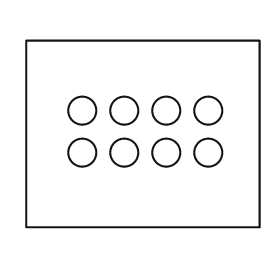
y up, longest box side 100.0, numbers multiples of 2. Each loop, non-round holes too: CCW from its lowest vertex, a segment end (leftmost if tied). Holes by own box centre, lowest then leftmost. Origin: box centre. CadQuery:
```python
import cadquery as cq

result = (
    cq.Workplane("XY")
    .moveTo(-50.0, -40.0)
    .lineTo(50.0, -40.0)
    .lineTo(50.0, 40.0)
    .lineTo(-50.0, 40.0)
    .close()
    .moveTo(-26.0, -8.0)
    .circle(6.0)
    .moveTo(-8.0, -8.0)
    .circle(6.0)
    .moveTo(10.0, -8.0)
    .circle(6.0)
    .moveTo(28.0, -8.0)
    .circle(6.0)
    .moveTo(-26.0, 10.0)
    .circle(6.0)
    .moveTo(-8.0, 10.0)
    .circle(6.0)
    .moveTo(10.0, 10.0)
    .circle(6.0)
    .moveTo(28.0, 10.0)
    .circle(6.0)
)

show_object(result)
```